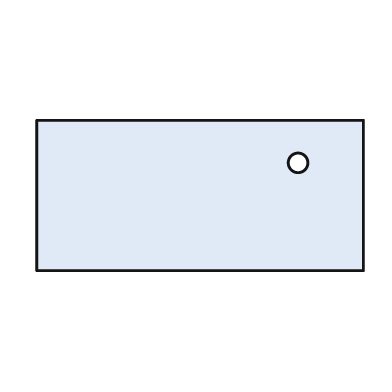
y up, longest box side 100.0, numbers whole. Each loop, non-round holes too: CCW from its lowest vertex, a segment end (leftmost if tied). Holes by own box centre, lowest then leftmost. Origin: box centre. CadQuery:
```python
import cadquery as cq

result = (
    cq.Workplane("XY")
    .moveTo(-50.0, -23.0)
    .lineTo(50.0, -23.0)
    .lineTo(50.0, 23.0)
    .lineTo(-50.0, 23.0)
    .close()
    .moveTo(30.0, 10.0)
    .circle(3.0)
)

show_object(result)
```